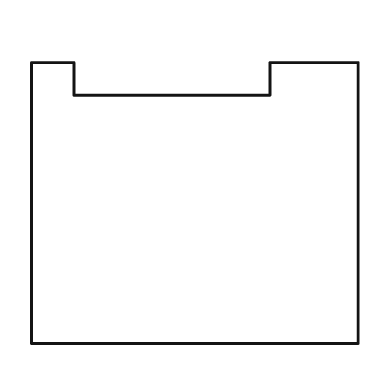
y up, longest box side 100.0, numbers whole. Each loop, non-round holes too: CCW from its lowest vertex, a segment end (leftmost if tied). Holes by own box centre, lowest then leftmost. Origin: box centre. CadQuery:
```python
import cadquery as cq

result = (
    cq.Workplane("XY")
    .moveTo(-50.0, -43.0)
    .lineTo(50.0, -43.0)
    .lineTo(50.0, 43.0)
    .lineTo(23.0, 43.0)
    .lineTo(23.0, 33.0)
    .lineTo(-37.0, 33.0)
    .lineTo(-37.0, 43.0)
    .lineTo(-50.0, 43.0)
    .close()
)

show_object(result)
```